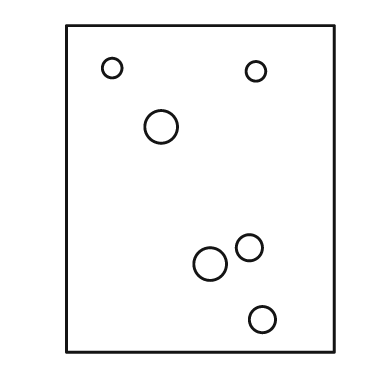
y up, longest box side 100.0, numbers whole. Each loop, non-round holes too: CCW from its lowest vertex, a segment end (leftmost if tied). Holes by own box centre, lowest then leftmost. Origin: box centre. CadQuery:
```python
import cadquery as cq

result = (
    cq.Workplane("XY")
    .moveTo(-41.0, -50.0)
    .lineTo(41.0, -50.0)
    .lineTo(41.0, 50.0)
    .lineTo(-41.0, 50.0)
    .close()
    .moveTo(19.0, -40.0)
    .circle(4.0)
    .moveTo(3.0, -23.0)
    .circle(5.0)
    .moveTo(15.0, -18.0)
    .circle(4.0)
    .moveTo(-12.0, 19.0)
    .circle(5.0)
    .moveTo(17.0, 36.0)
    .circle(3.0)
    .moveTo(-27.0, 37.0)
    .circle(3.0)
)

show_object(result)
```